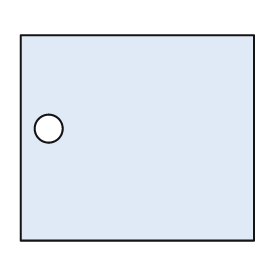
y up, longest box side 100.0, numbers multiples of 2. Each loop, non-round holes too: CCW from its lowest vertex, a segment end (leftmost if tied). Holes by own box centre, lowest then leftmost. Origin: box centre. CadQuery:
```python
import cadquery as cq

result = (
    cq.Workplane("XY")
    .moveTo(-50.0, -44.0)
    .lineTo(50.0, -44.0)
    .lineTo(50.0, 44.0)
    .lineTo(-50.0, 44.0)
    .close()
    .moveTo(-38.0, 4.0)
    .circle(6.0)
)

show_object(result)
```